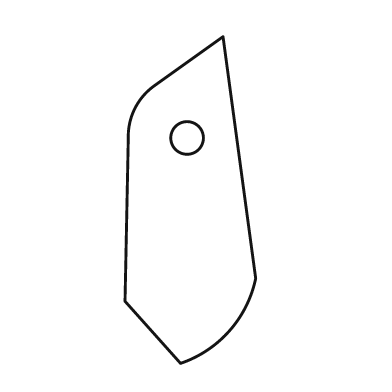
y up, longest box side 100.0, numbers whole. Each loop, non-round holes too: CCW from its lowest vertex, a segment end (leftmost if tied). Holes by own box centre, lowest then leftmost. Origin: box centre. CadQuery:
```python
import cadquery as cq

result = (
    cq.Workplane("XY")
    .moveTo(-3.0, -50.0)
    .threePointArc((12.0, -40.0), (20.0, -24.0))
    .lineTo(10.0, 50.0)
    .lineTo(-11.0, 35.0)
    .threePointArc((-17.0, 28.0), (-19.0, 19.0))
    .lineTo(-20.0, -31.0)
    .close()
    .moveTo(-1.0, 19.0)
    .circle(5.0)
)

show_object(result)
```